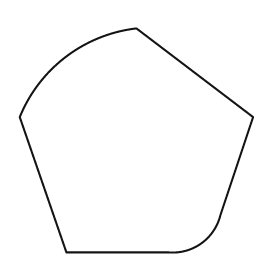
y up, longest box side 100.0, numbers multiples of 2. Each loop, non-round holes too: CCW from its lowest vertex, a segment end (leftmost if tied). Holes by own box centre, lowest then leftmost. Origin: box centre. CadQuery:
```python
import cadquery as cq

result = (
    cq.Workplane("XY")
    .moveTo(-30.0, -48.0)
    .lineTo(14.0, -48.0)
    .threePointArc((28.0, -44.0), (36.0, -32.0))
    .lineTo(50.0, 10.0)
    .lineTo(0.0, 48.0)
    .threePointArc((-30.0, 36.0), (-50.0, 10.0))
    .close()
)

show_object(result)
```